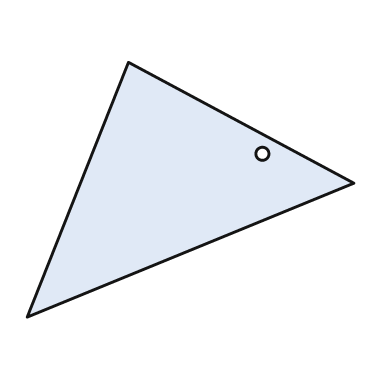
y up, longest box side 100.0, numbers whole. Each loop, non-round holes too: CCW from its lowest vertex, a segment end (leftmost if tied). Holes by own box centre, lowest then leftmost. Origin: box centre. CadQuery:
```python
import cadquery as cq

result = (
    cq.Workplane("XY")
    .moveTo(-50.0, -39.0)
    .lineTo(50.0, 2.0)
    .lineTo(-19.0, 39.0)
    .close()
    .moveTo(22.0, 11.0)
    .circle(2.0)
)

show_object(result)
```